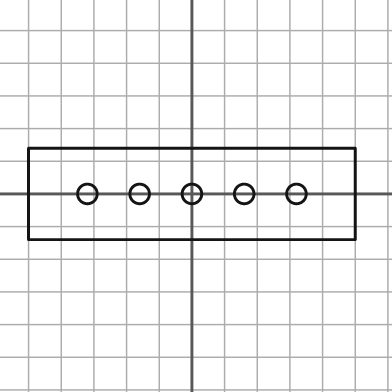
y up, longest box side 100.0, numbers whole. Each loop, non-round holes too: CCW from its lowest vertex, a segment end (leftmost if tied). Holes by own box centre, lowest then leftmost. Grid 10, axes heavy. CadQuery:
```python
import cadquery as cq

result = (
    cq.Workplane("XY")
    .moveTo(-50.0, -14.0)
    .lineTo(50.0, -14.0)
    .lineTo(50.0, 14.0)
    .lineTo(-50.0, 14.0)
    .close()
    .moveTo(-32.0, 0.0)
    .circle(3.0)
    .moveTo(-16.0, 0.0)
    .circle(3.0)
    .moveTo(0.0, 0.0)
    .circle(3.0)
    .moveTo(16.0, 0.0)
    .circle(3.0)
    .moveTo(32.0, 0.0)
    .circle(3.0)
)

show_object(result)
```